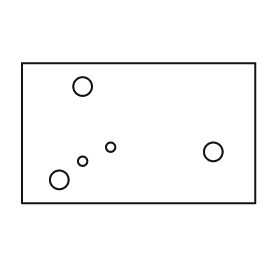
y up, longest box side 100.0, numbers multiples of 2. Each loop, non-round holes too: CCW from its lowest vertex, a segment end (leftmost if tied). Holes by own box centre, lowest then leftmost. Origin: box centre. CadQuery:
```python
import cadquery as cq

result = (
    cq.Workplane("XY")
    .moveTo(-50.0, -30.0)
    .lineTo(50.0, -30.0)
    .lineTo(50.0, 30.0)
    .lineTo(-50.0, 30.0)
    .close()
    .moveTo(-34.0, -20.0)
    .circle(4.0)
    .moveTo(-24.0, -12.0)
    .circle(2.0)
    .moveTo(32.0, -8.0)
    .circle(4.0)
    .moveTo(-12.0, -6.0)
    .circle(2.0)
    .moveTo(-24.0, 20.0)
    .circle(4.0)
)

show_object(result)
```